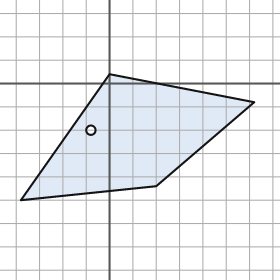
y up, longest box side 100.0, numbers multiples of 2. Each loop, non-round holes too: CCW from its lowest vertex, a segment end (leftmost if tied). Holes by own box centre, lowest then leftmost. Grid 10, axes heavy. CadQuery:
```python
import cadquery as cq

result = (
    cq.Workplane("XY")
    .moveTo(-38.0, -50.0)
    .lineTo(20.0, -44.0)
    .lineTo(62.0, -8.0)
    .lineTo(0.0, 4.0)
    .close()
    .moveTo(-8.0, -20.0)
    .circle(2.0)
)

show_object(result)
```